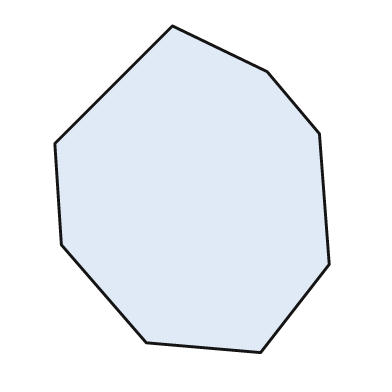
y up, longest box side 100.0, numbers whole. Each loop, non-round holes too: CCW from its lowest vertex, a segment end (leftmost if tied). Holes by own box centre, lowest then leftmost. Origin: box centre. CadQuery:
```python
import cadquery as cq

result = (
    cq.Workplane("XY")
    .moveTo(21.0, -50.0)
    .lineTo(42.0, -23.0)
    .lineTo(39.0, 17.0)
    .lineTo(23.0, 36.0)
    .lineTo(-6.0, 50.0)
    .lineTo(-42.0, 14.0)
    .lineTo(-40.0, -17.0)
    .lineTo(-14.0, -47.0)
    .close()
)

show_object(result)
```